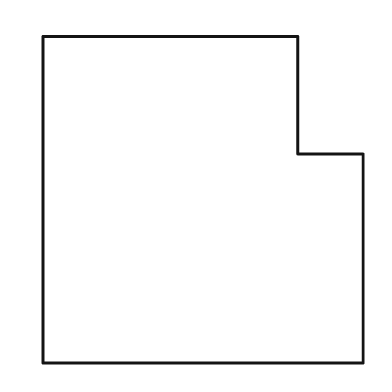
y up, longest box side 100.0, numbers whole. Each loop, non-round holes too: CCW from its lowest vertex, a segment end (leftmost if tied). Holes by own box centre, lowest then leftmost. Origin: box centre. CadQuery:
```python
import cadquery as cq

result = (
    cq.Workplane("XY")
    .moveTo(-49.0, -50.0)
    .lineTo(49.0, -50.0)
    .lineTo(49.0, 14.0)
    .lineTo(29.0, 14.0)
    .lineTo(29.0, 50.0)
    .lineTo(-49.0, 50.0)
    .close()
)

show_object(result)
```